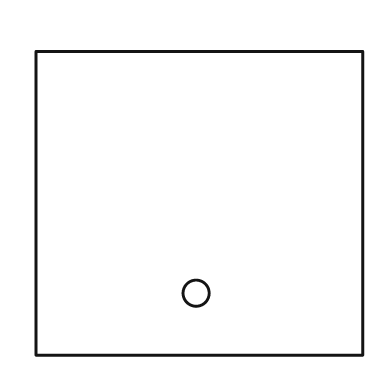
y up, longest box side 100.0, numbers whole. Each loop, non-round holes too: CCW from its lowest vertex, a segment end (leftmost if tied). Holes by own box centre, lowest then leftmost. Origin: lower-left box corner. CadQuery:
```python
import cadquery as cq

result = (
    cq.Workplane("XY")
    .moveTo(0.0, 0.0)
    .lineTo(100.0, 0.0)
    .lineTo(100.0, 93.0)
    .lineTo(0.0, 93.0)
    .close()
    .moveTo(49.0, 19.0)
    .circle(4.0)
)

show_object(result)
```